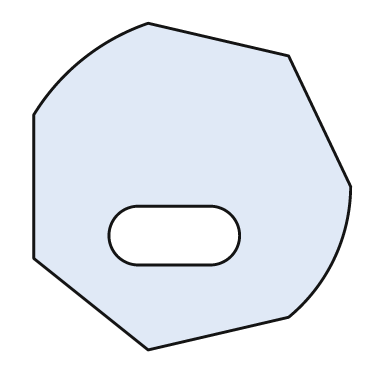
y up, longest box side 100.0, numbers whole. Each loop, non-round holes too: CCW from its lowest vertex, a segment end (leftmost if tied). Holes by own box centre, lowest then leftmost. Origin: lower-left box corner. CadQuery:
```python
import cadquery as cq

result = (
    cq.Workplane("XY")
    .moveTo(35.0, 0.0)
    .lineTo(78.0, 10.0)
    .threePointArc((92.0, 28.0), (97.0, 50.0))
    .lineTo(78.0, 90.0)
    .lineTo(35.0, 100.0)
    .threePointArc((15.0, 89.0), (0.0, 72.0))
    .lineTo(0.0, 28.0)
    .close()
    .moveTo(32.0, 26.0)
    .lineTo(54.0, 26.0)
    .threePointArc((63.0, 35.0), (54.0, 44.0))
    .lineTo(32.0, 44.0)
    .threePointArc((23.0, 35.0), (32.0, 26.0))
    .close()
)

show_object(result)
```